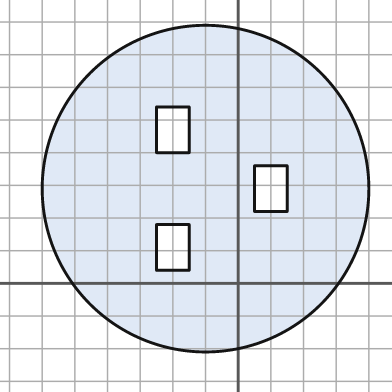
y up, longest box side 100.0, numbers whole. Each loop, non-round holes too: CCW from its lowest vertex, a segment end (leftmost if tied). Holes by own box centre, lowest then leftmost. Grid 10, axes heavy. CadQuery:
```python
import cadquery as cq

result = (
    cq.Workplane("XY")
    .moveTo(-10.0, 29.0)
    .circle(50.0)
    .moveTo(-25.0, 4.0)
    .lineTo(-15.0, 4.0)
    .lineTo(-15.0, 18.0)
    .lineTo(-25.0, 18.0)
    .close()
    .moveTo(5.0, 22.0)
    .lineTo(15.0, 22.0)
    .lineTo(15.0, 36.0)
    .lineTo(5.0, 36.0)
    .close()
    .moveTo(-25.0, 40.0)
    .lineTo(-15.0, 40.0)
    .lineTo(-15.0, 54.0)
    .lineTo(-25.0, 54.0)
    .close()
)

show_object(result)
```